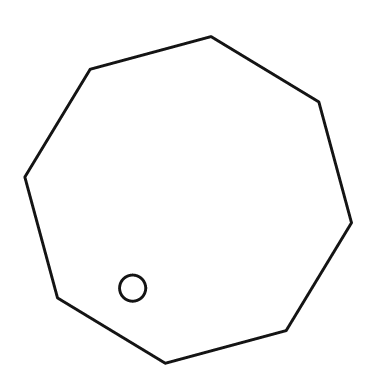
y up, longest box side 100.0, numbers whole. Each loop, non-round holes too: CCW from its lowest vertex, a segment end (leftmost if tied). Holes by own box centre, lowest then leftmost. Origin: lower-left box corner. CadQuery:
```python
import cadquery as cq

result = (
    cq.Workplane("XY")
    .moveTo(43.0, 0.0)
    .lineTo(80.0, 10.0)
    .lineTo(100.0, 43.0)
    .lineTo(90.0, 80.0)
    .lineTo(57.0, 100.0)
    .lineTo(20.0, 90.0)
    .lineTo(0.0, 57.0)
    .lineTo(10.0, 20.0)
    .close()
    .moveTo(33.0, 23.0)
    .circle(4.0)
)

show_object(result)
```